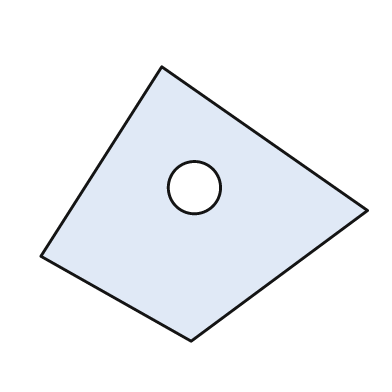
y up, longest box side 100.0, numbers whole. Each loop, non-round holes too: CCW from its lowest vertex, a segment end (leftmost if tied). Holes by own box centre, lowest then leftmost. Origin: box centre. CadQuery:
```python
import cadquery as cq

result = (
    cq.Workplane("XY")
    .moveTo(-4.0, -42.0)
    .lineTo(50.0, -2.0)
    .lineTo(-13.0, 42.0)
    .lineTo(-50.0, -16.0)
    .close()
    .moveTo(-3.0, 5.0)
    .circle(8.0)
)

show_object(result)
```